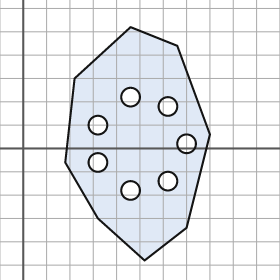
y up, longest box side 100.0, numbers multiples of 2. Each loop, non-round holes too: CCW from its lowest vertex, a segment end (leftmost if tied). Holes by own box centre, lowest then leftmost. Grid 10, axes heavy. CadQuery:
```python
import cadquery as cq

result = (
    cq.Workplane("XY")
    .moveTo(52.0, -48.0)
    .lineTo(70.0, -34.0)
    .lineTo(80.0, 6.0)
    .lineTo(66.0, 44.0)
    .lineTo(46.0, 52.0)
    .lineTo(22.0, 30.0)
    .lineTo(18.0, -6.0)
    .lineTo(32.0, -30.0)
    .close()
    .moveTo(46.0, -18.0)
    .circle(4.0)
    .moveTo(62.0, -14.0)
    .circle(4.0)
    .moveTo(32.0, -6.0)
    .circle(4.0)
    .moveTo(70.0, 2.0)
    .circle(4.0)
    .moveTo(32.0, 10.0)
    .circle(4.0)
    .moveTo(62.0, 18.0)
    .circle(4.0)
    .moveTo(46.0, 22.0)
    .circle(4.0)
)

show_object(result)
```